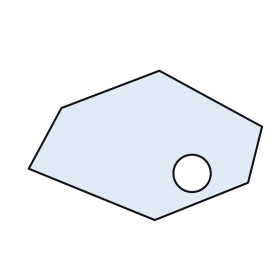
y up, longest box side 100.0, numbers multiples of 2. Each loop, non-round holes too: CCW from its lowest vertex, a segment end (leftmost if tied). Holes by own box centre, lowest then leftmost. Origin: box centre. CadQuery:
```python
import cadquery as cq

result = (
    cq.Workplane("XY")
    .moveTo(4.0, -32.0)
    .lineTo(44.0, -16.0)
    .lineTo(50.0, 8.0)
    .lineTo(6.0, 32.0)
    .lineTo(-36.0, 16.0)
    .lineTo(-50.0, -10.0)
    .close()
    .moveTo(20.0, -12.0)
    .circle(8.0)
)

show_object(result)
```